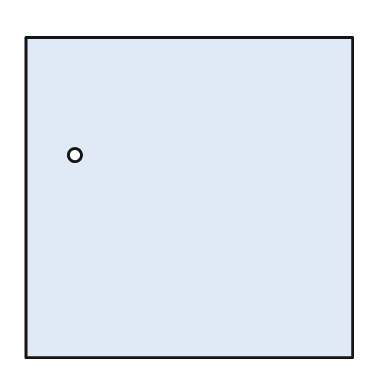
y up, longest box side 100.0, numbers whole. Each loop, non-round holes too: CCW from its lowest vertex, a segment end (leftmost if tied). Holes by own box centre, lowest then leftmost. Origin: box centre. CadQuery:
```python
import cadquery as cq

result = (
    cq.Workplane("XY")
    .moveTo(-50.0, -49.0)
    .lineTo(50.0, -49.0)
    .lineTo(50.0, 49.0)
    .lineTo(-50.0, 49.0)
    .close()
    .moveTo(-35.0, 13.0)
    .circle(2.0)
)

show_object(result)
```